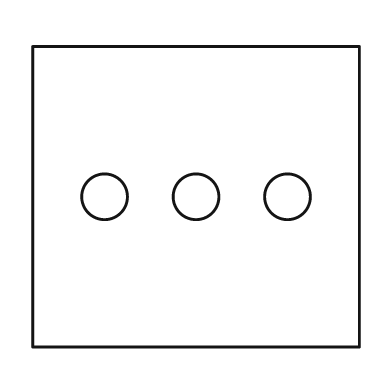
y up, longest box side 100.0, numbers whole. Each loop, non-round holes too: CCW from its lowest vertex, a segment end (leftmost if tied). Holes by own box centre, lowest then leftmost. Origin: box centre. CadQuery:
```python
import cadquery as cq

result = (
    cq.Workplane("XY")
    .moveTo(-50.0, -46.0)
    .lineTo(50.0, -46.0)
    .lineTo(50.0, 46.0)
    .lineTo(-50.0, 46.0)
    .close()
    .moveTo(-28.0, 0.0)
    .circle(7.0)
    .moveTo(0.0, 0.0)
    .circle(7.0)
    .moveTo(28.0, 0.0)
    .circle(7.0)
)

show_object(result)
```